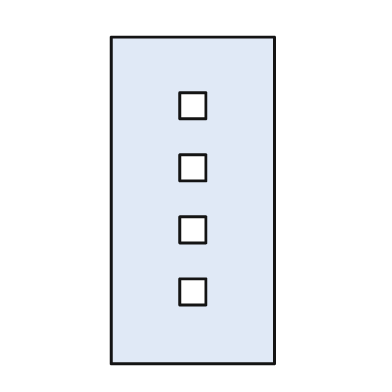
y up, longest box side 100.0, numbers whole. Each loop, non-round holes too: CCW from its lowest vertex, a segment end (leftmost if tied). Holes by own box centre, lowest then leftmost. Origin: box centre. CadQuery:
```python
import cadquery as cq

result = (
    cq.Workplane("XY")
    .moveTo(-25.0, -50.0)
    .lineTo(25.0, -50.0)
    .lineTo(25.0, 50.0)
    .lineTo(-25.0, 50.0)
    .close()
    .moveTo(-4.0, -32.0)
    .lineTo(4.0, -32.0)
    .lineTo(4.0, -24.0)
    .lineTo(-4.0, -24.0)
    .close()
    .moveTo(-4.0, -13.0)
    .lineTo(4.0, -13.0)
    .lineTo(4.0, -5.0)
    .lineTo(-4.0, -5.0)
    .close()
    .moveTo(-4.0, 6.0)
    .lineTo(4.0, 6.0)
    .lineTo(4.0, 14.0)
    .lineTo(-4.0, 14.0)
    .close()
    .moveTo(-4.0, 25.0)
    .lineTo(4.0, 25.0)
    .lineTo(4.0, 33.0)
    .lineTo(-4.0, 33.0)
    .close()
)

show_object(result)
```